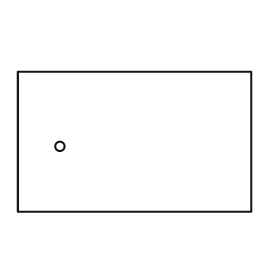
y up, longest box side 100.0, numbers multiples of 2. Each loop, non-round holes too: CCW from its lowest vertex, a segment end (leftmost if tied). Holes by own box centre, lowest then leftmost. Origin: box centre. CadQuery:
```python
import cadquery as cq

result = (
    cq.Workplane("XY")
    .moveTo(-50.0, -30.0)
    .lineTo(50.0, -30.0)
    .lineTo(50.0, 30.0)
    .lineTo(-50.0, 30.0)
    .close()
    .moveTo(-32.0, -2.0)
    .circle(2.0)
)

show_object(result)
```